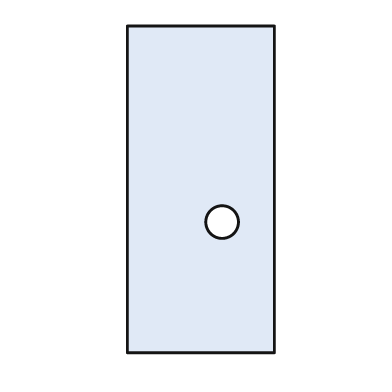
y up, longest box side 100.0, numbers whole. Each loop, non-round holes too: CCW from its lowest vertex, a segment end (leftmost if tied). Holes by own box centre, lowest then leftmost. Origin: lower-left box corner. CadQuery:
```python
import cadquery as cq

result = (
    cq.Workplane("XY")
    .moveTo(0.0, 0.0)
    .lineTo(45.0, 0.0)
    .lineTo(45.0, 100.0)
    .lineTo(0.0, 100.0)
    .close()
    .moveTo(29.0, 40.0)
    .circle(5.0)
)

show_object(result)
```